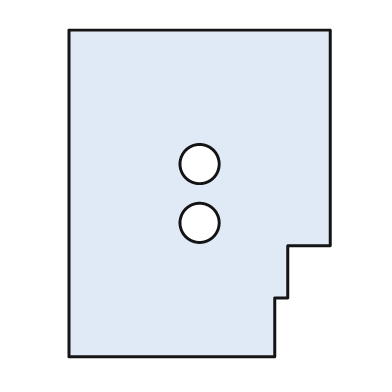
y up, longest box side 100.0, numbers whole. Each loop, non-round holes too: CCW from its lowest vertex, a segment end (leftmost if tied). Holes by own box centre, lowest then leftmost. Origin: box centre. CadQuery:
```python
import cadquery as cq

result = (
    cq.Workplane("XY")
    .moveTo(-40.0, -50.0)
    .lineTo(23.0, -50.0)
    .lineTo(23.0, -32.0)
    .lineTo(27.0, -32.0)
    .lineTo(27.0, -16.0)
    .lineTo(40.0, -16.0)
    .lineTo(40.0, 50.0)
    .lineTo(-40.0, 50.0)
    .close()
    .moveTo(0.0, -9.0)
    .circle(6.0)
    .moveTo(0.0, 9.0)
    .circle(6.0)
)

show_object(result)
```